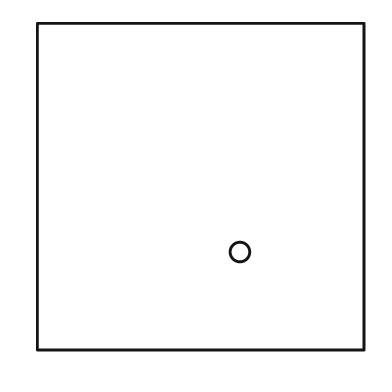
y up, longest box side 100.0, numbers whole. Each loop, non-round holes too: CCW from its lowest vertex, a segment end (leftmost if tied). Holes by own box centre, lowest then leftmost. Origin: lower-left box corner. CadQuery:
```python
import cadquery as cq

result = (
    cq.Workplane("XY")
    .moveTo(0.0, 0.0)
    .lineTo(100.0, 0.0)
    .lineTo(100.0, 100.0)
    .lineTo(0.0, 100.0)
    .close()
    .moveTo(62.0, 30.0)
    .circle(3.0)
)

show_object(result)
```